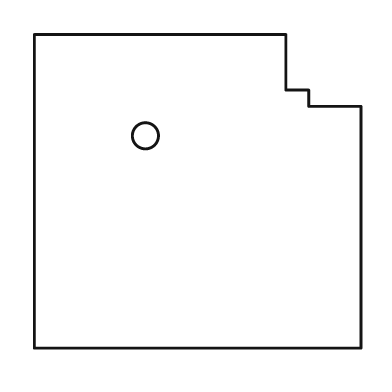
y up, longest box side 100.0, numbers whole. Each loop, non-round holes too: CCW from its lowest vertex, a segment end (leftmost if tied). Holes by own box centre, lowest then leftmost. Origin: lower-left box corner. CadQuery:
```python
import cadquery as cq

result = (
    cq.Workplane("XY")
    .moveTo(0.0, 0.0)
    .lineTo(100.0, 0.0)
    .lineTo(100.0, 74.0)
    .lineTo(84.0, 74.0)
    .lineTo(84.0, 79.0)
    .lineTo(77.0, 79.0)
    .lineTo(77.0, 96.0)
    .lineTo(0.0, 96.0)
    .close()
    .moveTo(34.0, 65.0)
    .circle(4.0)
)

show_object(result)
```